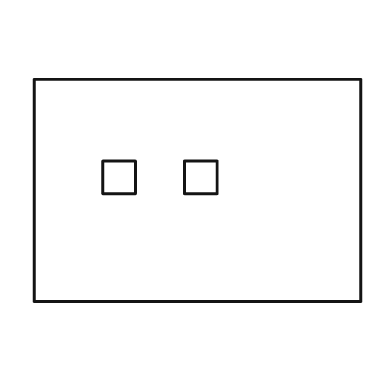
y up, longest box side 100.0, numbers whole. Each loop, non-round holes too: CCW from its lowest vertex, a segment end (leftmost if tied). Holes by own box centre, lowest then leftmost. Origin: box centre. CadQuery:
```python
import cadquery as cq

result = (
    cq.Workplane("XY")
    .moveTo(-50.0, -34.0)
    .lineTo(50.0, -34.0)
    .lineTo(50.0, 34.0)
    .lineTo(-50.0, 34.0)
    .close()
    .moveTo(-29.0, -1.0)
    .lineTo(-19.0, -1.0)
    .lineTo(-19.0, 9.0)
    .lineTo(-29.0, 9.0)
    .close()
    .moveTo(-4.0, -1.0)
    .lineTo(6.0, -1.0)
    .lineTo(6.0, 9.0)
    .lineTo(-4.0, 9.0)
    .close()
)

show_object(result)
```